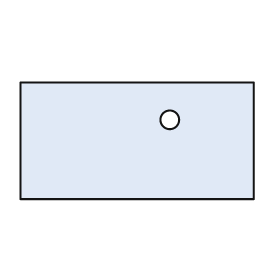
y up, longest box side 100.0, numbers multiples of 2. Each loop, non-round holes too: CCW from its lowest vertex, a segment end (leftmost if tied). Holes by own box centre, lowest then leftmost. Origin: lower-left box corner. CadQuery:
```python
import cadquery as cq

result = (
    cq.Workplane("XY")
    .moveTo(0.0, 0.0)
    .lineTo(100.0, 0.0)
    .lineTo(100.0, 50.0)
    .lineTo(0.0, 50.0)
    .close()
    .moveTo(64.0, 34.0)
    .circle(4.0)
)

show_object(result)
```